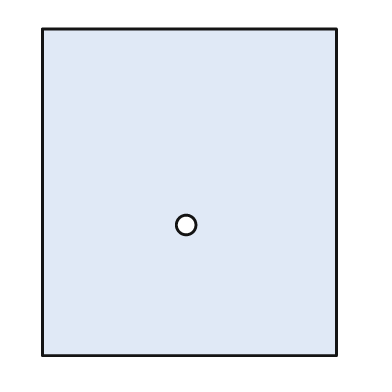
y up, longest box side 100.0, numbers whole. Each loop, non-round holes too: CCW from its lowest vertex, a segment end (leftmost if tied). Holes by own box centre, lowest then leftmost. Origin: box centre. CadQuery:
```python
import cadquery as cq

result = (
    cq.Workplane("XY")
    .moveTo(-45.0, -50.0)
    .lineTo(45.0, -50.0)
    .lineTo(45.0, 50.0)
    .lineTo(-45.0, 50.0)
    .close()
    .moveTo(-1.0, -10.0)
    .circle(3.0)
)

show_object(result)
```